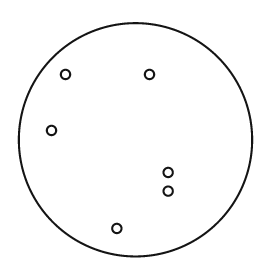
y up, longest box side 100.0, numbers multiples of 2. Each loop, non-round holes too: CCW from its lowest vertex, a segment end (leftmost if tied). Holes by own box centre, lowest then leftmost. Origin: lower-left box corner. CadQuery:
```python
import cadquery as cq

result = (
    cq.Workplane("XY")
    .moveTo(50.0, 50.0)
    .circle(50.0)
    .moveTo(42.0, 12.0)
    .circle(2.0)
    .moveTo(64.0, 28.0)
    .circle(2.0)
    .moveTo(64.0, 36.0)
    .circle(2.0)
    .moveTo(14.0, 54.0)
    .circle(2.0)
    .moveTo(20.0, 78.0)
    .circle(2.0)
    .moveTo(56.0, 78.0)
    .circle(2.0)
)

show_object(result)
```